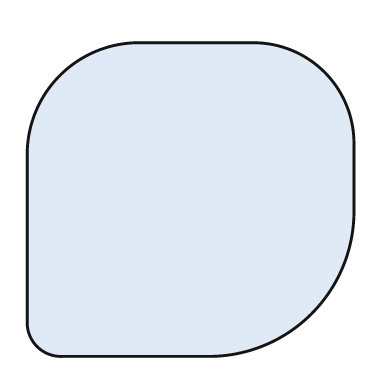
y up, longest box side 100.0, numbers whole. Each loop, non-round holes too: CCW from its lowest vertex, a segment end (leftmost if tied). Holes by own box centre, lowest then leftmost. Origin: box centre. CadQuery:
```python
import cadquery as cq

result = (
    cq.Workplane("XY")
    .moveTo(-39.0, -48.0)
    .lineTo(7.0, -48.0)
    .threePointArc((37.0, -35.0), (50.0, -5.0))
    .lineTo(50.0, 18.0)
    .threePointArc((41.0, 39.0), (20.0, 48.0))
    .lineTo(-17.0, 48.0)
    .threePointArc((-40.0, 38.0), (-50.0, 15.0))
    .lineTo(-50.0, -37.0)
    .threePointArc((-47.0, -45.0), (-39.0, -48.0))
    .close()
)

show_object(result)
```